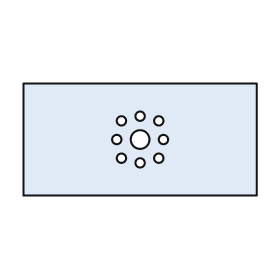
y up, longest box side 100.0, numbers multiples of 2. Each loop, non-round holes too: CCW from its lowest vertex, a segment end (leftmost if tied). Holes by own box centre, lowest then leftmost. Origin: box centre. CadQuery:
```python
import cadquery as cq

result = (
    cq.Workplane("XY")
    .moveTo(-50.0, -24.0)
    .lineTo(50.0, -24.0)
    .lineTo(50.0, 24.0)
    .lineTo(-50.0, 24.0)
    .close()
    .moveTo(0.0, -10.0)
    .circle(2.0)
    .moveTo(-8.0, -8.0)
    .circle(2.0)
    .moveTo(8.0, -8.0)
    .circle(2.0)
    .moveTo(-10.0, 0.0)
    .circle(2.0)
    .moveTo(0.0, 0.0)
    .circle(4.0)
    .moveTo(10.0, 0.0)
    .circle(2.0)
    .moveTo(-8.0, 8.0)
    .circle(2.0)
    .moveTo(8.0, 8.0)
    .circle(2.0)
    .moveTo(0.0, 10.0)
    .circle(2.0)
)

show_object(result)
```